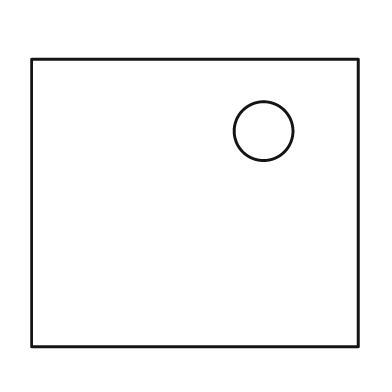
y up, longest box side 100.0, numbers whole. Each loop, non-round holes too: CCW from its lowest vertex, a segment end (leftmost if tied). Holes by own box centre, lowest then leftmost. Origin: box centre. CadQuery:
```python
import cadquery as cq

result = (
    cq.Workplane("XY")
    .moveTo(-50.0, -44.0)
    .lineTo(50.0, -44.0)
    .lineTo(50.0, 44.0)
    .lineTo(-50.0, 44.0)
    .close()
    .moveTo(21.0, 22.0)
    .circle(9.0)
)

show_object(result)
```